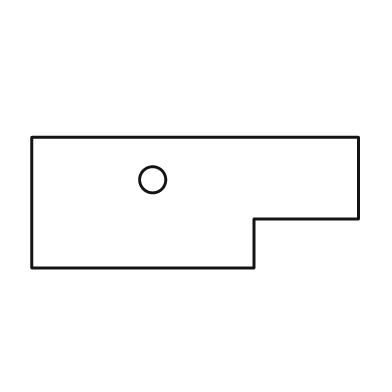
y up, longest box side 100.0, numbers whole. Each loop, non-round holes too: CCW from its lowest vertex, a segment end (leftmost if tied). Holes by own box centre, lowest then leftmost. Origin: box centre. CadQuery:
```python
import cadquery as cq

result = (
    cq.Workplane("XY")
    .moveTo(-50.0, -20.0)
    .lineTo(18.0, -20.0)
    .lineTo(18.0, -5.0)
    .lineTo(50.0, -5.0)
    .lineTo(50.0, 20.0)
    .lineTo(-50.0, 20.0)
    .close()
    .moveTo(-13.0, 7.0)
    .circle(4.0)
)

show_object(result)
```